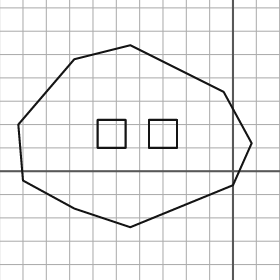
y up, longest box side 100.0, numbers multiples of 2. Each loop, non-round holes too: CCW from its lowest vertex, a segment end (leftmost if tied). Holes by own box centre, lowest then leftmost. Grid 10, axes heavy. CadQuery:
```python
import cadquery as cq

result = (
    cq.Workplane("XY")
    .moveTo(-44.0, -24.0)
    .lineTo(0.0, -6.0)
    .lineTo(8.0, 12.0)
    .lineTo(-4.0, 34.0)
    .lineTo(-44.0, 54.0)
    .lineTo(-68.0, 48.0)
    .lineTo(-92.0, 20.0)
    .lineTo(-90.0, -4.0)
    .lineTo(-68.0, -16.0)
    .close()
    .moveTo(-58.0, 10.0)
    .lineTo(-46.0, 10.0)
    .lineTo(-46.0, 22.0)
    .lineTo(-58.0, 22.0)
    .close()
    .moveTo(-36.0, 10.0)
    .lineTo(-24.0, 10.0)
    .lineTo(-24.0, 22.0)
    .lineTo(-36.0, 22.0)
    .close()
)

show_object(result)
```